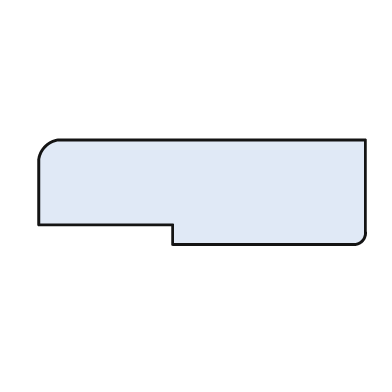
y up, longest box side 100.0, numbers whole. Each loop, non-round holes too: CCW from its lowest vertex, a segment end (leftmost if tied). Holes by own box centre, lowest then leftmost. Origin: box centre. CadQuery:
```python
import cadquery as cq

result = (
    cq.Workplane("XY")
    .moveTo(-9.0, -16.0)
    .lineTo(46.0, -16.0)
    .threePointArc((49.0, -15.0), (50.0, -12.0))
    .lineTo(50.0, 16.0)
    .lineTo(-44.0, 16.0)
    .threePointArc((-48.0, 14.0), (-50.0, 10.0))
    .lineTo(-50.0, -10.0)
    .lineTo(-9.0, -10.0)
    .close()
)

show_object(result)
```